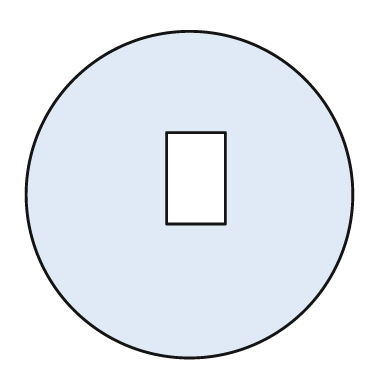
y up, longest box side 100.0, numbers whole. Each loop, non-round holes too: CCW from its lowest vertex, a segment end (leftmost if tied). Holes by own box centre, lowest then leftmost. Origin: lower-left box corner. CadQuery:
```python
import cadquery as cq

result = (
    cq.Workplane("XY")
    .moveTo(50.0, 50.0)
    .circle(50.0)
    .moveTo(43.0, 41.0)
    .lineTo(61.0, 41.0)
    .lineTo(61.0, 69.0)
    .lineTo(43.0, 69.0)
    .close()
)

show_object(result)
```